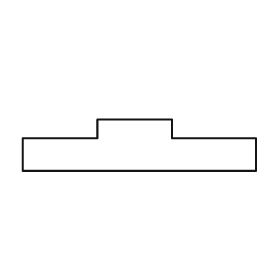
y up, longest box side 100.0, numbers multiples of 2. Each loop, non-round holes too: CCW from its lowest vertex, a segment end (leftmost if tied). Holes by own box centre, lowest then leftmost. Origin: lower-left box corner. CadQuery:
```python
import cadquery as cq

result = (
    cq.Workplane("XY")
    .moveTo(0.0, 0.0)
    .lineTo(100.0, 0.0)
    .lineTo(100.0, 14.0)
    .lineTo(64.0, 14.0)
    .lineTo(64.0, 22.0)
    .lineTo(32.0, 22.0)
    .lineTo(32.0, 14.0)
    .lineTo(0.0, 14.0)
    .close()
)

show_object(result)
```